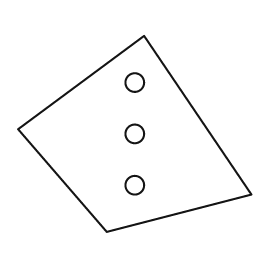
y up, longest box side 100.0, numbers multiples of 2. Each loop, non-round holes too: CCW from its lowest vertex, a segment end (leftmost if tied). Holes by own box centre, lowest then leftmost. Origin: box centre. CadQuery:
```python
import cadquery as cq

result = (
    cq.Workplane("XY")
    .moveTo(-12.0, -42.0)
    .lineTo(50.0, -26.0)
    .lineTo(4.0, 42.0)
    .lineTo(-50.0, 2.0)
    .close()
    .moveTo(0.0, -22.0)
    .circle(4.0)
    .moveTo(0.0, 0.0)
    .circle(4.0)
    .moveTo(0.0, 22.0)
    .circle(4.0)
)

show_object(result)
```